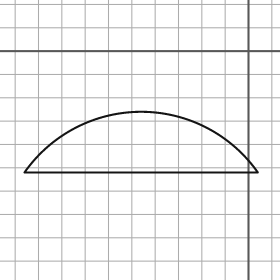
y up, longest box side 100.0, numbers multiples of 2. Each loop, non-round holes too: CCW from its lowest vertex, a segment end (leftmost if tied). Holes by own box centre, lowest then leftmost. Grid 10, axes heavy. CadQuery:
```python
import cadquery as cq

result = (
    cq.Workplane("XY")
    .moveTo(-96.0, -52.0)
    .lineTo(4.0, -52.0)
    .threePointArc((-46.0, -26.0), (-96.0, -52.0))
    .close()
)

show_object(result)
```